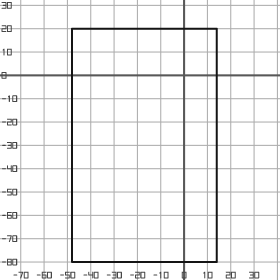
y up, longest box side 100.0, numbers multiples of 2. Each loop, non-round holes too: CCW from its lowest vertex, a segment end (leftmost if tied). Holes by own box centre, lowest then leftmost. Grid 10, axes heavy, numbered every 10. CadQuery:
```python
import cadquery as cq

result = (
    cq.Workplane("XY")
    .moveTo(-48.0, -80.0)
    .lineTo(14.0, -80.0)
    .lineTo(14.0, 20.0)
    .lineTo(-48.0, 20.0)
    .close()
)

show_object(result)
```